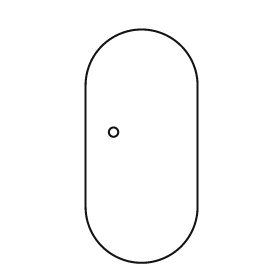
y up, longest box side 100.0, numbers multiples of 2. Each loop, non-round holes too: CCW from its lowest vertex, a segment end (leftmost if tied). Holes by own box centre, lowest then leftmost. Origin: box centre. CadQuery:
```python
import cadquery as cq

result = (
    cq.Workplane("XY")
    .moveTo(-24.0, -26.0)
    .threePointArc((0.0, -50.0), (24.0, -26.0))
    .lineTo(24.0, 26.0)
    .threePointArc((0.0, 50.0), (-24.0, 26.0))
    .close()
    .moveTo(-12.0, 6.0)
    .circle(2.0)
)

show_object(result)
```